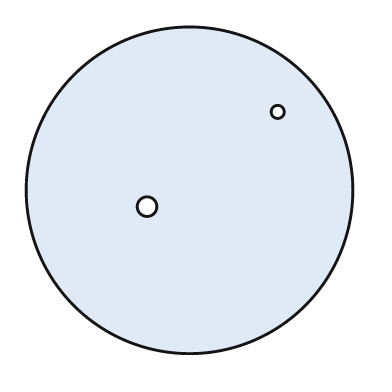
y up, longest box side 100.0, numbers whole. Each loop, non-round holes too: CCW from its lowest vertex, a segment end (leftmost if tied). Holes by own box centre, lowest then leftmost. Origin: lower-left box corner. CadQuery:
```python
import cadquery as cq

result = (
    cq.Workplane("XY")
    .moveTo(50.0, 50.0)
    .circle(50.0)
    .moveTo(37.0, 45.0)
    .circle(3.0)
    .moveTo(77.0, 74.0)
    .circle(2.0)
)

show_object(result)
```